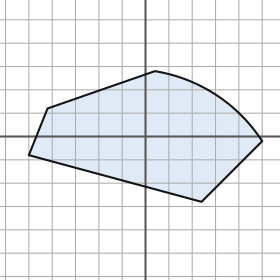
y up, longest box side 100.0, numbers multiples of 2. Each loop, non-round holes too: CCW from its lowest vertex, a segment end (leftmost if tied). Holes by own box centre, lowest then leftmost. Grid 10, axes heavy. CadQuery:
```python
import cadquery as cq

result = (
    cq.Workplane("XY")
    .moveTo(24.0, -28.0)
    .lineTo(50.0, -2.0)
    .threePointArc((30.0, 18.0), (4.0, 28.0))
    .lineTo(-42.0, 12.0)
    .lineTo(-50.0, -8.0)
    .close()
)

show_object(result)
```